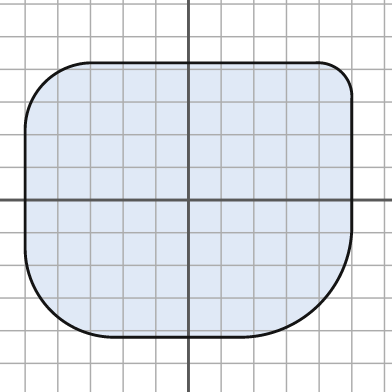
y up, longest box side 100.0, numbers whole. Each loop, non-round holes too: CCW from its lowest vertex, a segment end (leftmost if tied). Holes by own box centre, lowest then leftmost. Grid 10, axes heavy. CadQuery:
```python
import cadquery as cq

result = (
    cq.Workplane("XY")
    .moveTo(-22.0, -42.0)
    .lineTo(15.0, -42.0)
    .threePointArc((40.0, -32.0), (50.0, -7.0))
    .lineTo(50.0, 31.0)
    .threePointArc((47.0, 39.0), (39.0, 42.0))
    .lineTo(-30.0, 42.0)
    .threePointArc((-44.0, 36.0), (-50.0, 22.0))
    .lineTo(-50.0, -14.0)
    .threePointArc((-42.0, -34.0), (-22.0, -42.0))
    .close()
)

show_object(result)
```